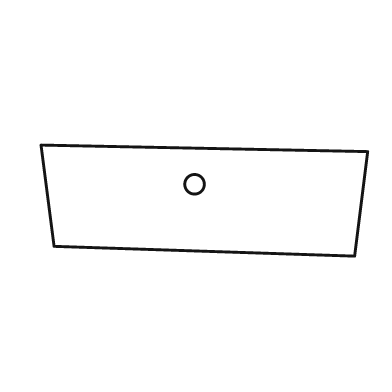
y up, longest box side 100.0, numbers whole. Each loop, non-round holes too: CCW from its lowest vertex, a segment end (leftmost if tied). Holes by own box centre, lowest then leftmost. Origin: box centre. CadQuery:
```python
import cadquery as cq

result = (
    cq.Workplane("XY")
    .moveTo(46.0, -17.0)
    .lineTo(50.0, 15.0)
    .lineTo(-50.0, 17.0)
    .lineTo(-46.0, -14.0)
    .close()
    .moveTo(-3.0, 5.0)
    .circle(3.0)
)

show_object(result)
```